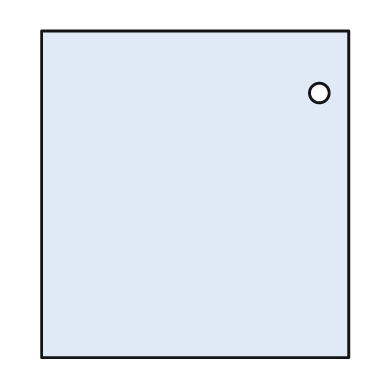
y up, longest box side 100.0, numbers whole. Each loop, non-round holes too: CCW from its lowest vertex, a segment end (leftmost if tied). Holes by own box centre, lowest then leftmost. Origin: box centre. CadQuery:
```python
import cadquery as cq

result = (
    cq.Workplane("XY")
    .moveTo(-47.0, -50.0)
    .lineTo(47.0, -50.0)
    .lineTo(47.0, 50.0)
    .lineTo(-47.0, 50.0)
    .close()
    .moveTo(38.0, 31.0)
    .circle(3.0)
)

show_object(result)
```